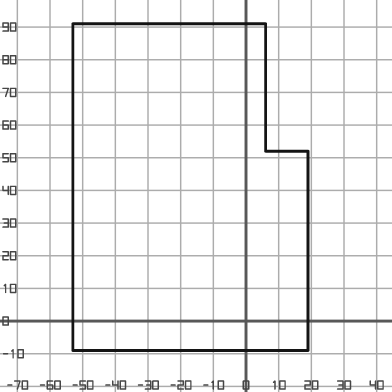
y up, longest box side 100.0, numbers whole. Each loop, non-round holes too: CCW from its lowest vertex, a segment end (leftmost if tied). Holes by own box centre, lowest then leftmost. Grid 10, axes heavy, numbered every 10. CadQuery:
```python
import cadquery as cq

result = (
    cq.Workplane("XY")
    .moveTo(-53.0, -9.0)
    .lineTo(19.0, -9.0)
    .lineTo(19.0, 52.0)
    .lineTo(6.0, 52.0)
    .lineTo(6.0, 91.0)
    .lineTo(-53.0, 91.0)
    .close()
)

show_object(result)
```